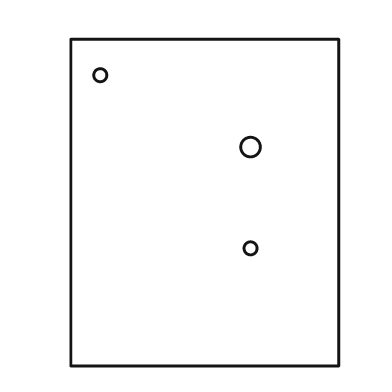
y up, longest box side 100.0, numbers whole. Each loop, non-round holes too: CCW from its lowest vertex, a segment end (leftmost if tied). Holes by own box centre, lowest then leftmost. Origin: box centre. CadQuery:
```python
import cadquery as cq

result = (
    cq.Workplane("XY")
    .moveTo(-41.0, -50.0)
    .lineTo(41.0, -50.0)
    .lineTo(41.0, 50.0)
    .lineTo(-41.0, 50.0)
    .close()
    .moveTo(14.0, -14.0)
    .circle(2.0)
    .moveTo(14.0, 17.0)
    .circle(3.0)
    .moveTo(-32.0, 39.0)
    .circle(2.0)
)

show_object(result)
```